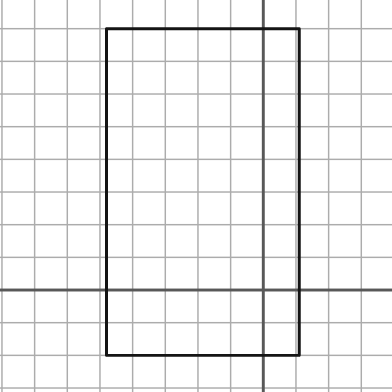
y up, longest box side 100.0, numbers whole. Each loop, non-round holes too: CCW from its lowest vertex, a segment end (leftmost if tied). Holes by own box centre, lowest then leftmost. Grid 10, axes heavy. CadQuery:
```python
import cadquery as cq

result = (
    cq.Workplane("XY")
    .moveTo(-48.0, -20.0)
    .lineTo(11.0, -20.0)
    .lineTo(11.0, 80.0)
    .lineTo(-48.0, 80.0)
    .close()
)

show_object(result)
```